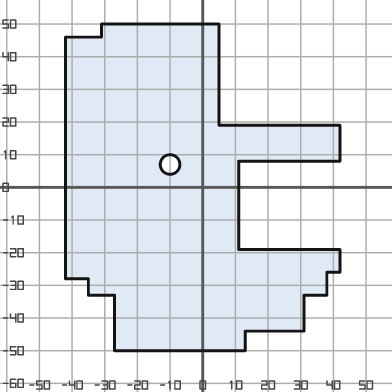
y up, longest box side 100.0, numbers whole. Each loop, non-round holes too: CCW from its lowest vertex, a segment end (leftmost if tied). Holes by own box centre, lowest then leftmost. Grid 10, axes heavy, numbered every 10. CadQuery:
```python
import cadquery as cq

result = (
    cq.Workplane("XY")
    .moveTo(-27.0, -50.0)
    .lineTo(13.0, -50.0)
    .lineTo(13.0, -44.0)
    .lineTo(31.0, -44.0)
    .lineTo(31.0, -33.0)
    .lineTo(38.0, -33.0)
    .lineTo(38.0, -26.0)
    .lineTo(42.0, -26.0)
    .lineTo(42.0, -19.0)
    .lineTo(11.0, -19.0)
    .lineTo(11.0, 8.0)
    .lineTo(42.0, 8.0)
    .lineTo(42.0, 19.0)
    .lineTo(5.0, 19.0)
    .lineTo(5.0, 50.0)
    .lineTo(-31.0, 50.0)
    .lineTo(-31.0, 46.0)
    .lineTo(-42.0, 46.0)
    .lineTo(-42.0, -28.0)
    .lineTo(-35.0, -28.0)
    .lineTo(-35.0, -33.0)
    .lineTo(-27.0, -33.0)
    .close()
    .moveTo(-10.0, 7.0)
    .circle(3.0)
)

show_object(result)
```